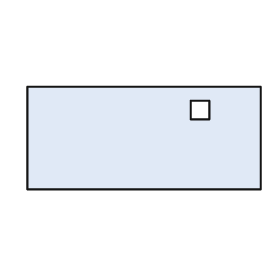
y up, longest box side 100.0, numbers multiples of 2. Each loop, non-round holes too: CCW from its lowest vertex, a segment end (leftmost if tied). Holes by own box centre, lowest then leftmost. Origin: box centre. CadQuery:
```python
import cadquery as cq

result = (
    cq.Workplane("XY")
    .moveTo(-50.0, -22.0)
    .lineTo(50.0, -22.0)
    .lineTo(50.0, 22.0)
    .lineTo(-50.0, 22.0)
    .close()
    .moveTo(20.0, 8.0)
    .lineTo(28.0, 8.0)
    .lineTo(28.0, 16.0)
    .lineTo(20.0, 16.0)
    .close()
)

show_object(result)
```